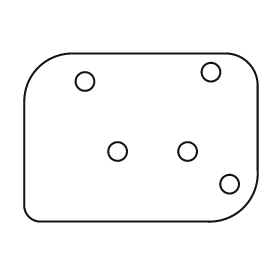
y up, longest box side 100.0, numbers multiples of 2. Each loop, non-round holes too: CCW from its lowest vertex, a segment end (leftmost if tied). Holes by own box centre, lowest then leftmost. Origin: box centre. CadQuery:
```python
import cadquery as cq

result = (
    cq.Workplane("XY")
    .moveTo(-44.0, -36.0)
    .lineTo(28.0, -36.0)
    .threePointArc((44.0, -30.0), (50.0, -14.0))
    .lineTo(50.0, 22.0)
    .threePointArc((46.0, 32.0), (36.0, 36.0))
    .lineTo(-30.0, 36.0)
    .threePointArc((-44.0, 30.0), (-50.0, 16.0))
    .lineTo(-50.0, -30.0)
    .threePointArc((-48.0, -34.0), (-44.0, -36.0))
    .close()
    .moveTo(38.0, -20.0)
    .circle(4.0)
    .moveTo(-10.0, -6.0)
    .circle(4.0)
    .moveTo(20.0, -6.0)
    .circle(4.0)
    .moveTo(-24.0, 24.0)
    .circle(4.0)
    .moveTo(30.0, 28.0)
    .circle(4.0)
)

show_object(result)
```